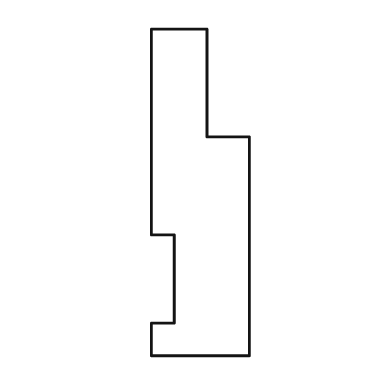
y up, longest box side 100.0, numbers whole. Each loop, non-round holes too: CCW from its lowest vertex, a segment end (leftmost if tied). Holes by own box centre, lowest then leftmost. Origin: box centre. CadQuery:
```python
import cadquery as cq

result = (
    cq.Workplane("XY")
    .moveTo(-15.0, -50.0)
    .lineTo(15.0, -50.0)
    .lineTo(15.0, 17.0)
    .lineTo(2.0, 17.0)
    .lineTo(2.0, 50.0)
    .lineTo(-15.0, 50.0)
    .lineTo(-15.0, -13.0)
    .lineTo(-8.0, -13.0)
    .lineTo(-8.0, -40.0)
    .lineTo(-15.0, -40.0)
    .close()
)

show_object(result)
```